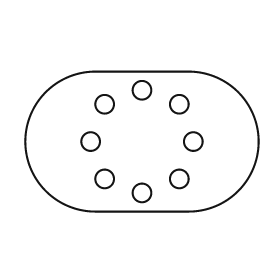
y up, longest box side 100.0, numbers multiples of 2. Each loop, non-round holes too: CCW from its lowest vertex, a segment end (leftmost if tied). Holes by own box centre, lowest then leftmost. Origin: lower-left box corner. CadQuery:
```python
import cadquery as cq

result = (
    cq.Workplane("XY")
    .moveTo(30.0, 0.0)
    .lineTo(70.0, 0.0)
    .threePointArc((100.0, 30.0), (70.0, 60.0))
    .lineTo(30.0, 60.0)
    .threePointArc((0.0, 30.0), (30.0, 0.0))
    .close()
    .moveTo(50.0, 8.0)
    .circle(4.0)
    .moveTo(34.0, 14.0)
    .circle(4.0)
    .moveTo(66.0, 14.0)
    .circle(4.0)
    .moveTo(28.0, 30.0)
    .circle(4.0)
    .moveTo(72.0, 30.0)
    .circle(4.0)
    .moveTo(34.0, 46.0)
    .circle(4.0)
    .moveTo(66.0, 46.0)
    .circle(4.0)
    .moveTo(50.0, 52.0)
    .circle(4.0)
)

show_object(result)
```